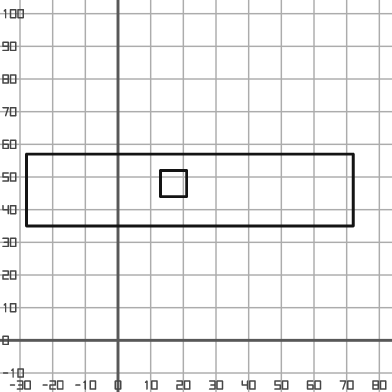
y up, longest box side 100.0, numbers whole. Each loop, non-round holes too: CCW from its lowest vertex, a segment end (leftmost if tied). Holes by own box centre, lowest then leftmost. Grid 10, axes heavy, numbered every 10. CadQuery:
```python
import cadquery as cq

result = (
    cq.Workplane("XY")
    .moveTo(-28.0, 35.0)
    .lineTo(72.0, 35.0)
    .lineTo(72.0, 57.0)
    .lineTo(-28.0, 57.0)
    .close()
    .moveTo(13.0, 44.0)
    .lineTo(21.0, 44.0)
    .lineTo(21.0, 52.0)
    .lineTo(13.0, 52.0)
    .close()
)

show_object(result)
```